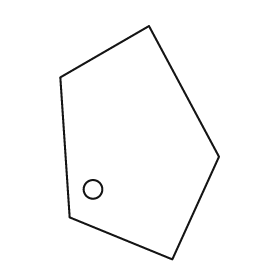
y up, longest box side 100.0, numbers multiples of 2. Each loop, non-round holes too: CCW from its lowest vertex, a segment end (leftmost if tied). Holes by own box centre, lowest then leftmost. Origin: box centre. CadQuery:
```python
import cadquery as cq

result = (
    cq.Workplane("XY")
    .moveTo(14.0, -50.0)
    .lineTo(34.0, -6.0)
    .lineTo(4.0, 50.0)
    .lineTo(-34.0, 28.0)
    .lineTo(-30.0, -32.0)
    .close()
    .moveTo(-20.0, -20.0)
    .circle(4.0)
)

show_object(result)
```